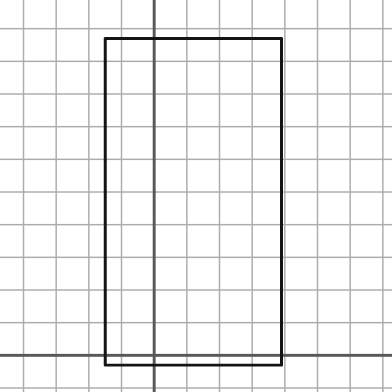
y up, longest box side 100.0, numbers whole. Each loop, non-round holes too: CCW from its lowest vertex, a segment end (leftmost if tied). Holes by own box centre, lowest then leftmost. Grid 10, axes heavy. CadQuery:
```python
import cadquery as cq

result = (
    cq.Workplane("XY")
    .moveTo(-15.0, -3.0)
    .lineTo(39.0, -3.0)
    .lineTo(39.0, 97.0)
    .lineTo(-15.0, 97.0)
    .close()
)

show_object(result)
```